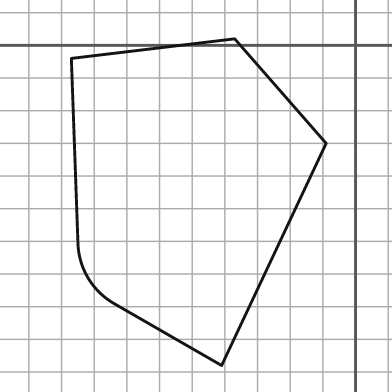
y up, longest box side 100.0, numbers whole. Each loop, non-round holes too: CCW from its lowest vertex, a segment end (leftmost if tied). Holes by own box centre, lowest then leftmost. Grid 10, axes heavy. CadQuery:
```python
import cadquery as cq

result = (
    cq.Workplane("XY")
    .moveTo(-41.0, -98.0)
    .lineTo(-9.0, -30.0)
    .lineTo(-37.0, 2.0)
    .lineTo(-87.0, -4.0)
    .lineTo(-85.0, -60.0)
    .threePointArc((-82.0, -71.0), (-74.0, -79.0))
    .close()
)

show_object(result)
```